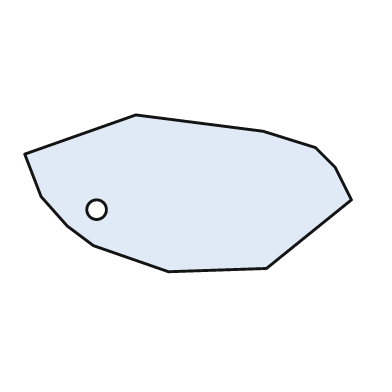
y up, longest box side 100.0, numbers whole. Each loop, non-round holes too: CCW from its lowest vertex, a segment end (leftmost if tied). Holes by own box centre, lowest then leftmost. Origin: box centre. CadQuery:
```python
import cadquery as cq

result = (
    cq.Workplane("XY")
    .moveTo(-6.0, -24.0)
    .lineTo(24.0, -23.0)
    .lineTo(50.0, -2.0)
    .lineTo(45.0, 8.0)
    .lineTo(39.0, 14.0)
    .lineTo(23.0, 19.0)
    .lineTo(-16.0, 24.0)
    .lineTo(-50.0, 12.0)
    .lineTo(-45.0, -1.0)
    .lineTo(-37.0, -10.0)
    .lineTo(-29.0, -16.0)
    .close()
    .moveTo(-28.0, -5.0)
    .circle(3.0)
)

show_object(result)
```